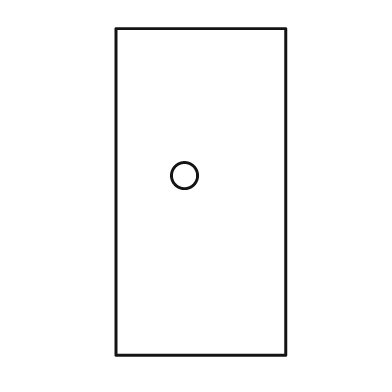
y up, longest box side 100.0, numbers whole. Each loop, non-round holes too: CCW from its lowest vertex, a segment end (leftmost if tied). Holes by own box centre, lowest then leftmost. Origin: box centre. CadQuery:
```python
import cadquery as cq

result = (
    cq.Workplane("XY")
    .moveTo(-26.0, -50.0)
    .lineTo(26.0, -50.0)
    .lineTo(26.0, 50.0)
    .lineTo(-26.0, 50.0)
    .close()
    .moveTo(-5.0, 5.0)
    .circle(4.0)
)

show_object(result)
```